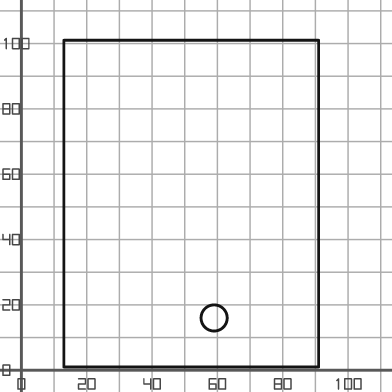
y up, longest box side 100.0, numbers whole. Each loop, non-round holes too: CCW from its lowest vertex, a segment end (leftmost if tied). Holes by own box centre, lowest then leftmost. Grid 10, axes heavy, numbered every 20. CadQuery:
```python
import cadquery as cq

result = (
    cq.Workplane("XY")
    .moveTo(13.0, 1.0)
    .lineTo(91.0, 1.0)
    .lineTo(91.0, 101.0)
    .lineTo(13.0, 101.0)
    .close()
    .moveTo(59.0, 16.0)
    .circle(4.0)
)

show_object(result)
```